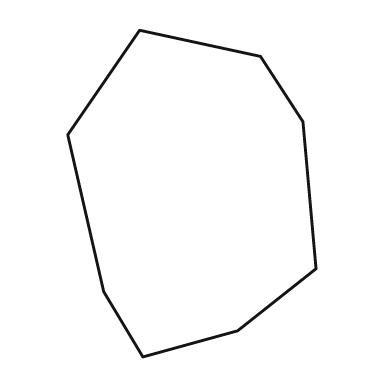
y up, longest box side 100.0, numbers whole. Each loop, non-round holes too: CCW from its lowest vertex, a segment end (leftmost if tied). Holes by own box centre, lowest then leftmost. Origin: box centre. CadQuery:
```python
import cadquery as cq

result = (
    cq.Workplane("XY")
    .moveTo(-15.0, -50.0)
    .lineTo(14.0, -42.0)
    .lineTo(38.0, -23.0)
    .lineTo(34.0, 22.0)
    .lineTo(21.0, 42.0)
    .lineTo(-16.0, 50.0)
    .lineTo(-38.0, 18.0)
    .lineTo(-27.0, -30.0)
    .close()
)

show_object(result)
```